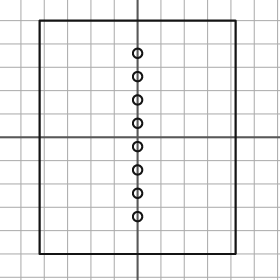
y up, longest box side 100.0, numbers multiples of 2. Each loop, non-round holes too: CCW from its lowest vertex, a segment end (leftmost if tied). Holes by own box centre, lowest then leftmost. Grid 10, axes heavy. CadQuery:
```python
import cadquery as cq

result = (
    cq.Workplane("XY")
    .moveTo(-42.0, -50.0)
    .lineTo(42.0, -50.0)
    .lineTo(42.0, 50.0)
    .lineTo(-42.0, 50.0)
    .close()
    .moveTo(0.0, -34.0)
    .circle(2.0)
    .moveTo(0.0, -24.0)
    .circle(2.0)
    .moveTo(0.0, -14.0)
    .circle(2.0)
    .moveTo(0.0, -4.0)
    .circle(2.0)
    .moveTo(0.0, 6.0)
    .circle(2.0)
    .moveTo(0.0, 16.0)
    .circle(2.0)
    .moveTo(0.0, 26.0)
    .circle(2.0)
    .moveTo(0.0, 36.0)
    .circle(2.0)
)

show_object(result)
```